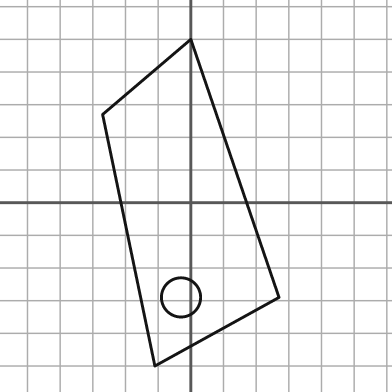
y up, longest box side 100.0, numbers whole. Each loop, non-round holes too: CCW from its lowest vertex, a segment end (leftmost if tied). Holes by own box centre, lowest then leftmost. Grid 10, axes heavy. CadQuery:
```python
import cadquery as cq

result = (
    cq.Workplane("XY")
    .moveTo(-11.0, -50.0)
    .lineTo(27.0, -29.0)
    .lineTo(0.0, 50.0)
    .lineTo(-27.0, 27.0)
    .close()
    .moveTo(-3.0, -29.0)
    .circle(6.0)
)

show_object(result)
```